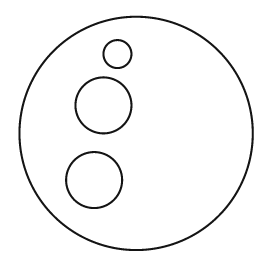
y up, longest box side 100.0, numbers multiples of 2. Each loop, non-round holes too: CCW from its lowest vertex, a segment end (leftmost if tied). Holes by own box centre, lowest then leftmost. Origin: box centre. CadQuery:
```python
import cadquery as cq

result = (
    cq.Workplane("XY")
    .moveTo(0.0, 0.0)
    .circle(50.0)
    .moveTo(-18.0, -20.0)
    .circle(12.0)
    .moveTo(-14.0, 12.0)
    .circle(12.0)
    .moveTo(-8.0, 34.0)
    .circle(6.0)
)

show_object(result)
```